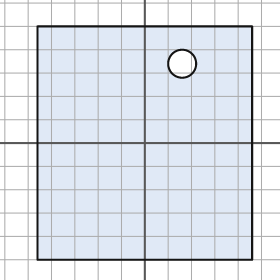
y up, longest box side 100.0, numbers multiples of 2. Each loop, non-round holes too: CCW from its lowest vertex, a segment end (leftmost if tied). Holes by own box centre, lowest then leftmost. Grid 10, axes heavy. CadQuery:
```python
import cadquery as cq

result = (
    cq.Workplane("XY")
    .moveTo(-46.0, -50.0)
    .lineTo(46.0, -50.0)
    .lineTo(46.0, 50.0)
    .lineTo(-46.0, 50.0)
    .close()
    .moveTo(16.0, 34.0)
    .circle(6.0)
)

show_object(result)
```